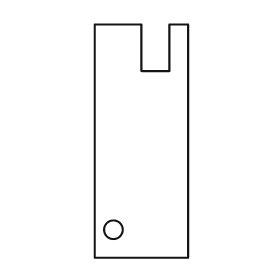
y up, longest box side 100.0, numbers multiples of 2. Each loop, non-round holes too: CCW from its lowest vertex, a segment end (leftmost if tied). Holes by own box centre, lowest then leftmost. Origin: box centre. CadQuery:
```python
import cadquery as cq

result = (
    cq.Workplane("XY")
    .moveTo(-20.0, -50.0)
    .lineTo(20.0, -50.0)
    .lineTo(20.0, 50.0)
    .lineTo(12.0, 50.0)
    .lineTo(12.0, 30.0)
    .lineTo(0.0, 30.0)
    .lineTo(0.0, 50.0)
    .lineTo(-20.0, 50.0)
    .close()
    .moveTo(-12.0, -38.0)
    .circle(4.0)
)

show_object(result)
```